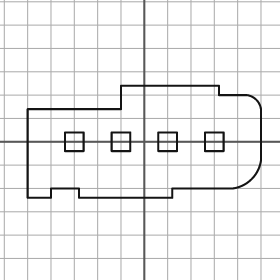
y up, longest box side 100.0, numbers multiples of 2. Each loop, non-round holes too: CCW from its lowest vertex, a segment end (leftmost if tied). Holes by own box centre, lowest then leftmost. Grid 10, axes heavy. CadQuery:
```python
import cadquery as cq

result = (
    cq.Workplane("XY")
    .moveTo(-50.0, -24.0)
    .lineTo(-40.0, -24.0)
    .lineTo(-40.0, -20.0)
    .lineTo(-28.0, -20.0)
    .lineTo(-28.0, -24.0)
    .lineTo(12.0, -24.0)
    .lineTo(12.0, -20.0)
    .lineTo(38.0, -20.0)
    .threePointArc((46.0, -16.0), (50.0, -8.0))
    .lineTo(50.0, 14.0)
    .threePointArc((48.0, 18.0), (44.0, 20.0))
    .lineTo(32.0, 20.0)
    .lineTo(32.0, 24.0)
    .lineTo(-10.0, 24.0)
    .lineTo(-10.0, 14.0)
    .lineTo(-50.0, 14.0)
    .close()
    .moveTo(-34.0, -4.0)
    .lineTo(-26.0, -4.0)
    .lineTo(-26.0, 4.0)
    .lineTo(-34.0, 4.0)
    .close()
    .moveTo(-14.0, -4.0)
    .lineTo(-6.0, -4.0)
    .lineTo(-6.0, 4.0)
    .lineTo(-14.0, 4.0)
    .close()
    .moveTo(6.0, -4.0)
    .lineTo(14.0, -4.0)
    .lineTo(14.0, 4.0)
    .lineTo(6.0, 4.0)
    .close()
    .moveTo(26.0, -4.0)
    .lineTo(34.0, -4.0)
    .lineTo(34.0, 4.0)
    .lineTo(26.0, 4.0)
    .close()
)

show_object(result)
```